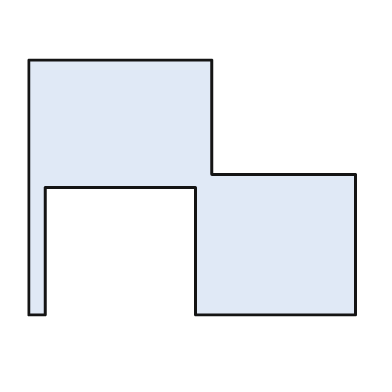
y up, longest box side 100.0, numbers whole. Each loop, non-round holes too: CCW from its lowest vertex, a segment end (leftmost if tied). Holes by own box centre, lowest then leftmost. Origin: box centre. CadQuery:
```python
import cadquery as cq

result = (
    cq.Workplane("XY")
    .moveTo(-50.0, -39.0)
    .lineTo(-45.0, -39.0)
    .lineTo(-45.0, 0.0)
    .lineTo(1.0, 0.0)
    .lineTo(1.0, -39.0)
    .lineTo(50.0, -39.0)
    .lineTo(50.0, 4.0)
    .lineTo(6.0, 4.0)
    .lineTo(6.0, 39.0)
    .lineTo(-50.0, 39.0)
    .close()
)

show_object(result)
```